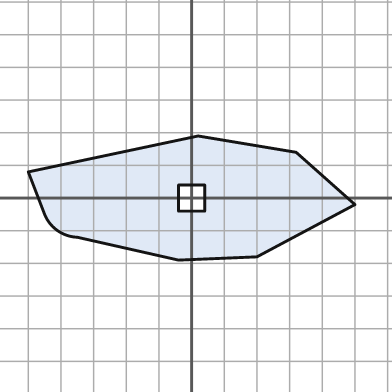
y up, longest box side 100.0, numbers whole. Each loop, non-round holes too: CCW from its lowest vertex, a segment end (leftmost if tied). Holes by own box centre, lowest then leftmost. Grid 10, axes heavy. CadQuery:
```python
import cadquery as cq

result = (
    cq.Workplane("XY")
    .moveTo(-4.0, -19.0)
    .lineTo(20.0, -18.0)
    .lineTo(50.0, -2.0)
    .lineTo(32.0, 14.0)
    .lineTo(2.0, 19.0)
    .lineTo(-50.0, 8.0)
    .lineTo(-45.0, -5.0)
    .threePointArc((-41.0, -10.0), (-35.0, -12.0))
    .close()
    .moveTo(-4.0, -4.0)
    .lineTo(4.0, -4.0)
    .lineTo(4.0, 4.0)
    .lineTo(-4.0, 4.0)
    .close()
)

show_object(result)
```